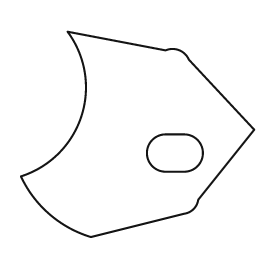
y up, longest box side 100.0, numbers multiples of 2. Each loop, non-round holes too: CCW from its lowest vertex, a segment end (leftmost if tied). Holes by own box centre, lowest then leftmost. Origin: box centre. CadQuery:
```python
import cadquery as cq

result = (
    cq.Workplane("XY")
    .moveTo(-20.0, -44.0)
    .lineTo(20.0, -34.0)
    .threePointArc((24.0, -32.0), (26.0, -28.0))
    .lineTo(50.0, 2.0)
    .lineTo(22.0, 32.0)
    .threePointArc((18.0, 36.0), (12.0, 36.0))
    .lineTo(-30.0, 44.0)
    .threePointArc((-24.0, 8.0), (-50.0, -18.0))
    .threePointArc((-38.0, -34.0), (-20.0, -44.0))
    .close()
    .moveTo(12.0, -16.0)
    .lineTo(20.0, -16.0)
    .threePointArc((28.0, -8.0), (20.0, 0.0))
    .lineTo(12.0, 0.0)
    .threePointArc((4.0, -8.0), (12.0, -16.0))
    .close()
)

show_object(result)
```